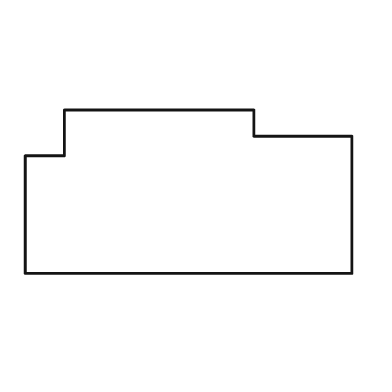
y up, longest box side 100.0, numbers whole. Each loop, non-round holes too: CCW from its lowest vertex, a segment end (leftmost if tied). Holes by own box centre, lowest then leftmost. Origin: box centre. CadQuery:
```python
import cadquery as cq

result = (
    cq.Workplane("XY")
    .moveTo(-50.0, -25.0)
    .lineTo(50.0, -25.0)
    .lineTo(50.0, 17.0)
    .lineTo(20.0, 17.0)
    .lineTo(20.0, 25.0)
    .lineTo(-38.0, 25.0)
    .lineTo(-38.0, 11.0)
    .lineTo(-50.0, 11.0)
    .close()
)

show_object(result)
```